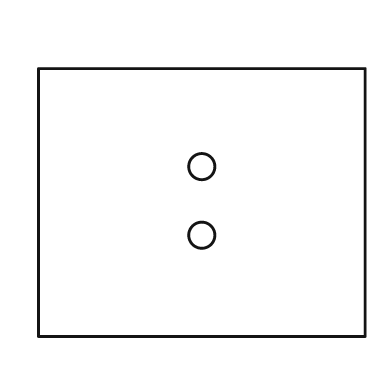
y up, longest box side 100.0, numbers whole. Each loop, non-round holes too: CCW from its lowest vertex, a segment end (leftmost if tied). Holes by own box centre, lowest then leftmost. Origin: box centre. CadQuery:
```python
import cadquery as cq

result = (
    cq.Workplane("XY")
    .moveTo(-50.0, -41.0)
    .lineTo(50.0, -41.0)
    .lineTo(50.0, 41.0)
    .lineTo(-50.0, 41.0)
    .close()
    .moveTo(0.0, -10.0)
    .circle(4.0)
    .moveTo(0.0, 11.0)
    .circle(4.0)
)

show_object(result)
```